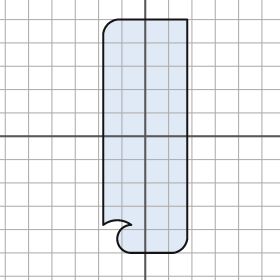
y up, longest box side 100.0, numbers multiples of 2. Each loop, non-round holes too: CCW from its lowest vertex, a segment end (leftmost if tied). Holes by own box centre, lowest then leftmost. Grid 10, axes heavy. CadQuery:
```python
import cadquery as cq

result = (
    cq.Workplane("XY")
    .moveTo(-6.0, -50.0)
    .lineTo(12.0, -50.0)
    .threePointArc((16.0, -48.0), (18.0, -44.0))
    .lineTo(18.0, 50.0)
    .lineTo(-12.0, 50.0)
    .threePointArc((-16.0, 48.0), (-18.0, 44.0))
    .lineTo(-18.0, -38.0)
    .threePointArc((-12.0, -36.0), (-6.0, -38.0))
    .threePointArc((-12.0, -44.0), (-6.0, -50.0))
    .close()
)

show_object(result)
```